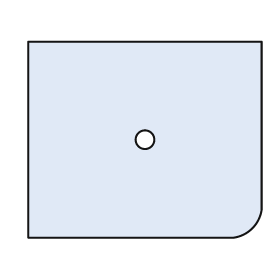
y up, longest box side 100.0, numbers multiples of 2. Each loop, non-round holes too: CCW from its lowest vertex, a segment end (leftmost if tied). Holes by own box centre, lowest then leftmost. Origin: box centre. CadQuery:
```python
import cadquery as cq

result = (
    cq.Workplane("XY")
    .moveTo(-50.0, -42.0)
    .lineTo(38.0, -42.0)
    .threePointArc((46.0, -38.0), (50.0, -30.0))
    .lineTo(50.0, 42.0)
    .lineTo(-50.0, 42.0)
    .close()
    .moveTo(0.0, 0.0)
    .circle(4.0)
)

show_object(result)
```